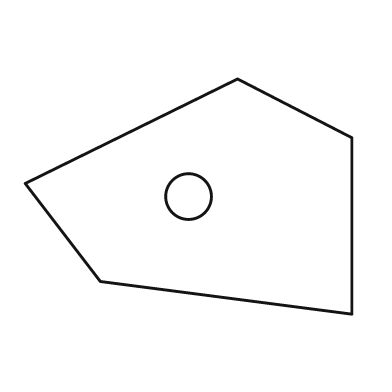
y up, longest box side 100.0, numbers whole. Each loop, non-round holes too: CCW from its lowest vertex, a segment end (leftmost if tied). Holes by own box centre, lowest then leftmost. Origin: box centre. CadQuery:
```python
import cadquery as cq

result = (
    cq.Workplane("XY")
    .moveTo(50.0, -36.0)
    .lineTo(50.0, 18.0)
    .lineTo(15.0, 36.0)
    .lineTo(-50.0, 4.0)
    .lineTo(-27.0, -26.0)
    .close()
    .moveTo(0.0, 0.0)
    .circle(7.0)
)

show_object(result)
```